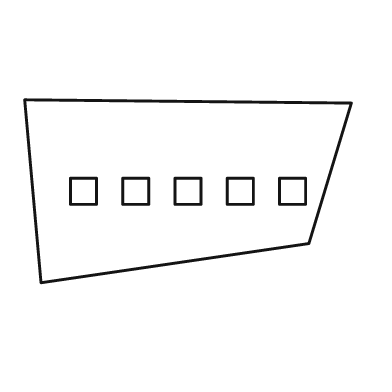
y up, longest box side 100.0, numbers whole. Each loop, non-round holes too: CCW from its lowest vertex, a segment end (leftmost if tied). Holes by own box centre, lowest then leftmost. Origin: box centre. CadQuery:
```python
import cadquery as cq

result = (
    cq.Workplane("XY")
    .moveTo(-45.0, -28.0)
    .lineTo(37.0, -16.0)
    .lineTo(50.0, 27.0)
    .lineTo(-50.0, 28.0)
    .close()
    .moveTo(-36.0, -4.0)
    .lineTo(-28.0, -4.0)
    .lineTo(-28.0, 4.0)
    .lineTo(-36.0, 4.0)
    .close()
    .moveTo(-20.0, -4.0)
    .lineTo(-12.0, -4.0)
    .lineTo(-12.0, 4.0)
    .lineTo(-20.0, 4.0)
    .close()
    .moveTo(-4.0, -4.0)
    .lineTo(4.0, -4.0)
    .lineTo(4.0, 4.0)
    .lineTo(-4.0, 4.0)
    .close()
    .moveTo(12.0, -4.0)
    .lineTo(20.0, -4.0)
    .lineTo(20.0, 4.0)
    .lineTo(12.0, 4.0)
    .close()
    .moveTo(28.0, -4.0)
    .lineTo(36.0, -4.0)
    .lineTo(36.0, 4.0)
    .lineTo(28.0, 4.0)
    .close()
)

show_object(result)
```